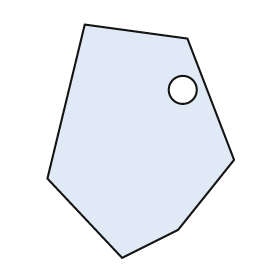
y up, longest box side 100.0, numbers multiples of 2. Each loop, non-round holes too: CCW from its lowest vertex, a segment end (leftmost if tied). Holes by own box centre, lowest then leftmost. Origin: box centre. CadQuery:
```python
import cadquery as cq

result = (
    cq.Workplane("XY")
    .moveTo(-8.0, -50.0)
    .lineTo(16.0, -38.0)
    .lineTo(40.0, -8.0)
    .lineTo(20.0, 44.0)
    .lineTo(-24.0, 50.0)
    .lineTo(-40.0, -16.0)
    .close()
    .moveTo(18.0, 22.0)
    .circle(6.0)
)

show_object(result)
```